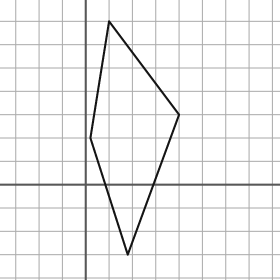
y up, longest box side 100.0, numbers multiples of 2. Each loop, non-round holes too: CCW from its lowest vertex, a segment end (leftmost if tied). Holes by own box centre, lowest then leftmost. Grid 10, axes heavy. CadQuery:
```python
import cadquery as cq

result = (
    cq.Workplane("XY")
    .moveTo(18.0, -30.0)
    .lineTo(40.0, 30.0)
    .lineTo(10.0, 70.0)
    .lineTo(2.0, 20.0)
    .close()
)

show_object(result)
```